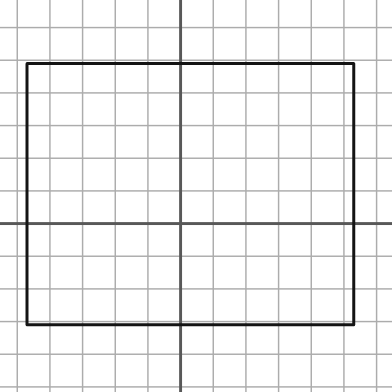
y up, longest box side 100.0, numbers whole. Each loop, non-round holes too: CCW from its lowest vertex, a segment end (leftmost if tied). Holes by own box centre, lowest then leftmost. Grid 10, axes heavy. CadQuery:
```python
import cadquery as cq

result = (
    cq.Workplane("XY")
    .moveTo(-47.0, -31.0)
    .lineTo(53.0, -31.0)
    .lineTo(53.0, 49.0)
    .lineTo(-47.0, 49.0)
    .close()
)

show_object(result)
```